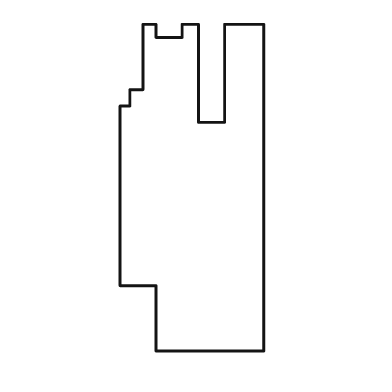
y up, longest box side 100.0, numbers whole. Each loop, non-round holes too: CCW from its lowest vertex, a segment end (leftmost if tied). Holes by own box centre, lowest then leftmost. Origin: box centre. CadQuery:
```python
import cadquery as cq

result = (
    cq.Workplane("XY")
    .moveTo(-11.0, -50.0)
    .lineTo(22.0, -50.0)
    .lineTo(22.0, 50.0)
    .lineTo(10.0, 50.0)
    .lineTo(10.0, 20.0)
    .lineTo(2.0, 20.0)
    .lineTo(2.0, 50.0)
    .lineTo(-3.0, 50.0)
    .lineTo(-3.0, 46.0)
    .lineTo(-11.0, 46.0)
    .lineTo(-11.0, 50.0)
    .lineTo(-15.0, 50.0)
    .lineTo(-15.0, 30.0)
    .lineTo(-19.0, 30.0)
    .lineTo(-19.0, 25.0)
    .lineTo(-22.0, 25.0)
    .lineTo(-22.0, -30.0)
    .lineTo(-11.0, -30.0)
    .close()
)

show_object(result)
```